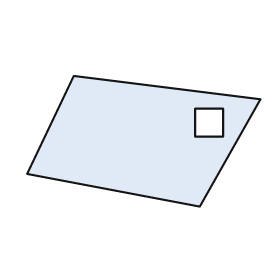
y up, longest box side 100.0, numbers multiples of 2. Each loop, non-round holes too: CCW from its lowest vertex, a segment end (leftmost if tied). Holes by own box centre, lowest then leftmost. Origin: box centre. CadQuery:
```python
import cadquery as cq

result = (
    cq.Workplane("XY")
    .moveTo(24.0, -28.0)
    .lineTo(50.0, 18.0)
    .lineTo(-30.0, 28.0)
    .lineTo(-50.0, -14.0)
    .close()
    .moveTo(22.0, 2.0)
    .lineTo(34.0, 2.0)
    .lineTo(34.0, 14.0)
    .lineTo(22.0, 14.0)
    .close()
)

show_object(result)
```